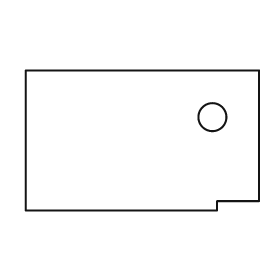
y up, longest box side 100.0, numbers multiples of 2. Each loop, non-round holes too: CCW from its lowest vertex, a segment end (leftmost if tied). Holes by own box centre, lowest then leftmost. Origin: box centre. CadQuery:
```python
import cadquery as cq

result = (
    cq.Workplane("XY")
    .moveTo(-50.0, -30.0)
    .lineTo(32.0, -30.0)
    .lineTo(32.0, -26.0)
    .lineTo(50.0, -26.0)
    .lineTo(50.0, 30.0)
    .lineTo(-50.0, 30.0)
    .close()
    .moveTo(30.0, 10.0)
    .circle(6.0)
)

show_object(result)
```